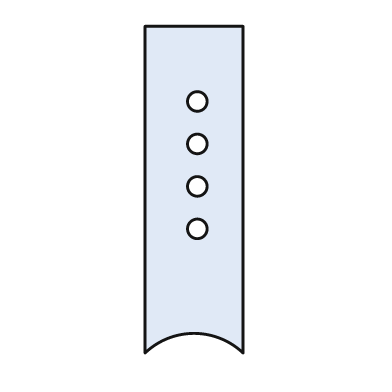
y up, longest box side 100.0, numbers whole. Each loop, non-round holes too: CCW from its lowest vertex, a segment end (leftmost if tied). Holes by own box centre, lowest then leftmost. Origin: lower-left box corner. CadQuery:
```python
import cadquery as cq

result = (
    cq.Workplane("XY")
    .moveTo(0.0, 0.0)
    .threePointArc((15.0, 6.0), (30.0, 0.0))
    .lineTo(30.0, 100.0)
    .lineTo(0.0, 100.0)
    .close()
    .moveTo(16.0, 38.0)
    .circle(3.0)
    .moveTo(16.0, 51.0)
    .circle(3.0)
    .moveTo(16.0, 64.0)
    .circle(3.0)
    .moveTo(16.0, 77.0)
    .circle(3.0)
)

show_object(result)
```